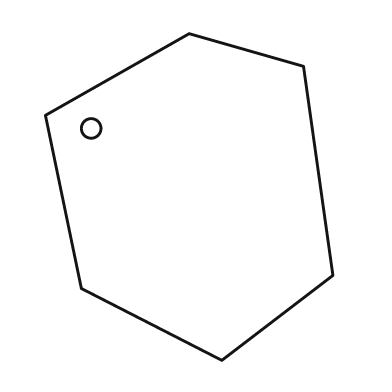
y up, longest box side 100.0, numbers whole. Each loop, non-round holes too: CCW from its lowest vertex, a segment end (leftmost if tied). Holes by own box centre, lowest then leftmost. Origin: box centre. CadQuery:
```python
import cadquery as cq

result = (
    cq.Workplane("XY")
    .moveTo(10.0, -50.0)
    .lineTo(44.0, -24.0)
    .lineTo(35.0, 40.0)
    .lineTo(0.0, 50.0)
    .lineTo(-44.0, 25.0)
    .lineTo(-33.0, -28.0)
    .close()
    .moveTo(-30.0, 21.0)
    .circle(3.0)
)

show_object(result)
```